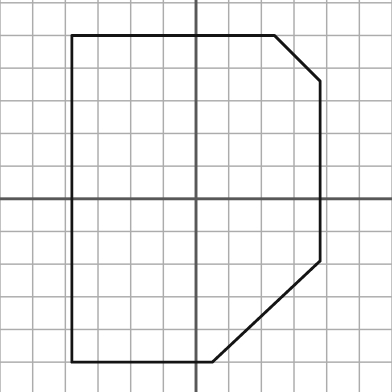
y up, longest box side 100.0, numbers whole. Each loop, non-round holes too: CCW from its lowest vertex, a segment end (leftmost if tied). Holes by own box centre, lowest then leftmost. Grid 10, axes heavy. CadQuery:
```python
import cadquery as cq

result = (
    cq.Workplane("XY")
    .moveTo(-38.0, -50.0)
    .lineTo(5.0, -50.0)
    .lineTo(38.0, -19.0)
    .lineTo(38.0, 36.0)
    .lineTo(24.0, 50.0)
    .lineTo(-38.0, 50.0)
    .close()
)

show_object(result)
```